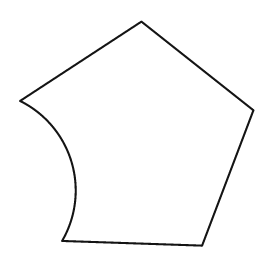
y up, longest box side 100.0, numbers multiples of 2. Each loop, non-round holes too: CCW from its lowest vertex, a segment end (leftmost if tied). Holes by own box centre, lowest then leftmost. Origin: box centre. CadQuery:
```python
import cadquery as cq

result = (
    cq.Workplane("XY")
    .moveTo(28.0, -48.0)
    .lineTo(50.0, 10.0)
    .lineTo(2.0, 48.0)
    .lineTo(-50.0, 14.0)
    .threePointArc((-28.0, -12.0), (-32.0, -46.0))
    .close()
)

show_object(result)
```